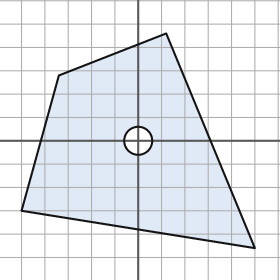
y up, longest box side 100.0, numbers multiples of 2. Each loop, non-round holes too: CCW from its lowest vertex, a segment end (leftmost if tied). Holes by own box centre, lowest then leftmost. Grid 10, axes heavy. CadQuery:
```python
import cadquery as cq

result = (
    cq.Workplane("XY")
    .moveTo(50.0, -46.0)
    .lineTo(12.0, 46.0)
    .lineTo(-34.0, 28.0)
    .lineTo(-50.0, -30.0)
    .close()
    .moveTo(0.0, 0.0)
    .circle(6.0)
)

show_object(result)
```